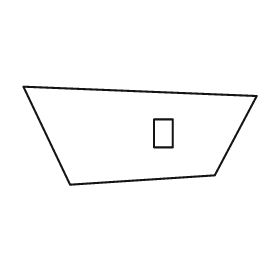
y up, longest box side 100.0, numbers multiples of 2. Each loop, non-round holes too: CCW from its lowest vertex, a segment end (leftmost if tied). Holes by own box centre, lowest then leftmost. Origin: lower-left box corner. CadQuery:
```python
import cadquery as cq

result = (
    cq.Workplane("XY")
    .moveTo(20.0, 0.0)
    .lineTo(82.0, 4.0)
    .lineTo(100.0, 38.0)
    .lineTo(0.0, 42.0)
    .close()
    .moveTo(56.0, 16.0)
    .lineTo(64.0, 16.0)
    .lineTo(64.0, 28.0)
    .lineTo(56.0, 28.0)
    .close()
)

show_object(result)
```